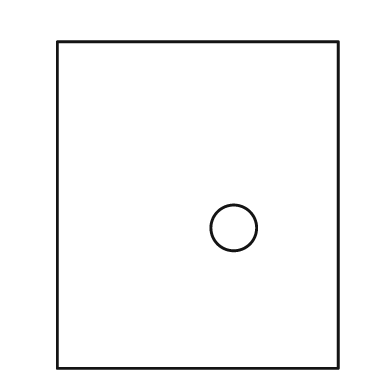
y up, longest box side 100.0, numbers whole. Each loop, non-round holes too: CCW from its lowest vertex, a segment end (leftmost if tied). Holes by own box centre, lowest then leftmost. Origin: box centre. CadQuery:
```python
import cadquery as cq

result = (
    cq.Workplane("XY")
    .moveTo(-43.0, -50.0)
    .lineTo(43.0, -50.0)
    .lineTo(43.0, 50.0)
    .lineTo(-43.0, 50.0)
    .close()
    .moveTo(11.0, -7.0)
    .circle(7.0)
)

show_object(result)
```